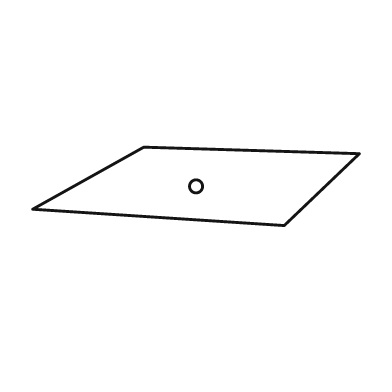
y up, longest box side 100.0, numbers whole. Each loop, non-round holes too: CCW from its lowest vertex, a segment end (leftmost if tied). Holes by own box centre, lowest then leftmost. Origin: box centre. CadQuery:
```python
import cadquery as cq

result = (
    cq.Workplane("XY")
    .moveTo(27.0, -12.0)
    .lineTo(50.0, 10.0)
    .lineTo(-16.0, 12.0)
    .lineTo(-50.0, -7.0)
    .close()
    .moveTo(0.0, 0.0)
    .circle(2.0)
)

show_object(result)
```